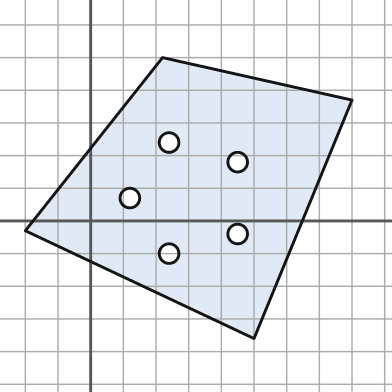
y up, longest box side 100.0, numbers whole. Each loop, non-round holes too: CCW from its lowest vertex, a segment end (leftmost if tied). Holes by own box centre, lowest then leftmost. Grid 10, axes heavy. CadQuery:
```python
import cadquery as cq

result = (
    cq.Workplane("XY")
    .moveTo(50.0, -36.0)
    .lineTo(80.0, 37.0)
    .lineTo(22.0, 50.0)
    .lineTo(-20.0, -3.0)
    .close()
    .moveTo(24.0, -10.0)
    .circle(3.0)
    .moveTo(45.0, -4.0)
    .circle(3.0)
    .moveTo(12.0, 7.0)
    .circle(3.0)
    .moveTo(45.0, 18.0)
    .circle(3.0)
    .moveTo(24.0, 24.0)
    .circle(3.0)
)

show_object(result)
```